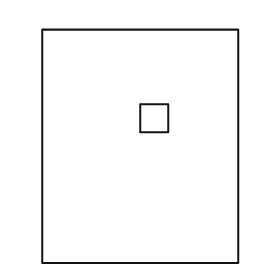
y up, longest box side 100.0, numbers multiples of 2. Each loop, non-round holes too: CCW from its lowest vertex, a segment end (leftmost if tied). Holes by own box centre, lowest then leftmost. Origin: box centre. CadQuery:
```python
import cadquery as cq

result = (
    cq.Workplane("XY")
    .moveTo(-42.0, -50.0)
    .lineTo(42.0, -50.0)
    .lineTo(42.0, 50.0)
    .lineTo(-42.0, 50.0)
    .close()
    .moveTo(0.0, 6.0)
    .lineTo(12.0, 6.0)
    .lineTo(12.0, 18.0)
    .lineTo(0.0, 18.0)
    .close()
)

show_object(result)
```